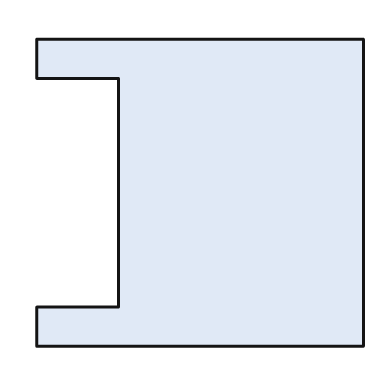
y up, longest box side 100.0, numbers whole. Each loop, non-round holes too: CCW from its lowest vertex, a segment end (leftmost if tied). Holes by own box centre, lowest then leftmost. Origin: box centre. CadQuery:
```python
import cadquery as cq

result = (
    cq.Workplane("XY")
    .moveTo(-50.0, -47.0)
    .lineTo(50.0, -47.0)
    .lineTo(50.0, 47.0)
    .lineTo(-50.0, 47.0)
    .lineTo(-50.0, 35.0)
    .lineTo(-25.0, 35.0)
    .lineTo(-25.0, -35.0)
    .lineTo(-50.0, -35.0)
    .close()
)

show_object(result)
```